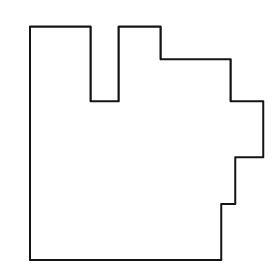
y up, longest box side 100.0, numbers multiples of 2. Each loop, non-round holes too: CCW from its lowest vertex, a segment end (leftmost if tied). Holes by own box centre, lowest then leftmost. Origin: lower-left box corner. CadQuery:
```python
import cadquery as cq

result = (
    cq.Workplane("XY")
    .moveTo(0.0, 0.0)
    .lineTo(82.0, 0.0)
    .lineTo(82.0, 24.0)
    .lineTo(88.0, 24.0)
    .lineTo(88.0, 44.0)
    .lineTo(100.0, 44.0)
    .lineTo(100.0, 68.0)
    .lineTo(86.0, 68.0)
    .lineTo(86.0, 86.0)
    .lineTo(56.0, 86.0)
    .lineTo(56.0, 100.0)
    .lineTo(38.0, 100.0)
    .lineTo(38.0, 68.0)
    .lineTo(26.0, 68.0)
    .lineTo(26.0, 100.0)
    .lineTo(0.0, 100.0)
    .close()
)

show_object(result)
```